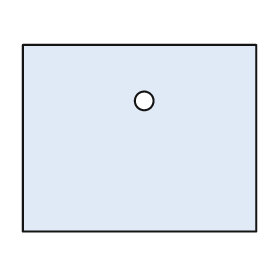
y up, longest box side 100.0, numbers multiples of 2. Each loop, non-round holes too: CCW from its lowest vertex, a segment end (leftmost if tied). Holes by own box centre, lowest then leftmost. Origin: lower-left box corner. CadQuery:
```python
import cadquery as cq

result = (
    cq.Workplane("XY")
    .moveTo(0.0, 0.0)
    .lineTo(100.0, 0.0)
    .lineTo(100.0, 80.0)
    .lineTo(0.0, 80.0)
    .close()
    .moveTo(52.0, 56.0)
    .circle(4.0)
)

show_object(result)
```